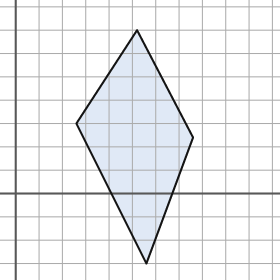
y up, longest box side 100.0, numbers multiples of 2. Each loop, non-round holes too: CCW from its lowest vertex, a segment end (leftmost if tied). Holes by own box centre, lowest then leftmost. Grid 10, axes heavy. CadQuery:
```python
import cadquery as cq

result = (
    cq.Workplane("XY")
    .moveTo(56.0, -30.0)
    .lineTo(76.0, 24.0)
    .lineTo(52.0, 70.0)
    .lineTo(26.0, 30.0)
    .close()
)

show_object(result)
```